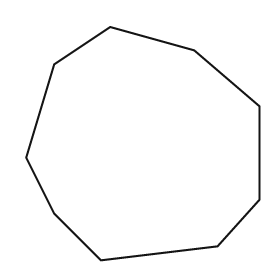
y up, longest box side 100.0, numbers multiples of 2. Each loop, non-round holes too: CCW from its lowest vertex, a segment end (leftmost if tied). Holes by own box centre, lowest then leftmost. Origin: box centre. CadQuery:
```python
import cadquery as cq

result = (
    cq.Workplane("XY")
    .moveTo(-18.0, -50.0)
    .lineTo(32.0, -44.0)
    .lineTo(50.0, -24.0)
    .lineTo(50.0, 16.0)
    .lineTo(22.0, 40.0)
    .lineTo(-14.0, 50.0)
    .lineTo(-38.0, 34.0)
    .lineTo(-50.0, -6.0)
    .lineTo(-38.0, -30.0)
    .close()
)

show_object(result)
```